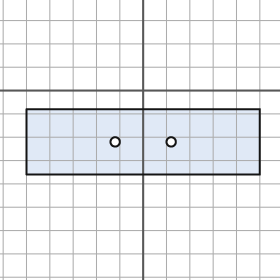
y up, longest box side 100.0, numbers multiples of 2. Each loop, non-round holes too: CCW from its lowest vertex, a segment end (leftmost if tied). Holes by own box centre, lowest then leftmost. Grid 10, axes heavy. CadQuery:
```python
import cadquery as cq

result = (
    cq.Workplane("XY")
    .moveTo(-50.0, -36.0)
    .lineTo(50.0, -36.0)
    .lineTo(50.0, -8.0)
    .lineTo(-50.0, -8.0)
    .close()
    .moveTo(-12.0, -22.0)
    .circle(2.0)
    .moveTo(12.0, -22.0)
    .circle(2.0)
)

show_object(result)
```